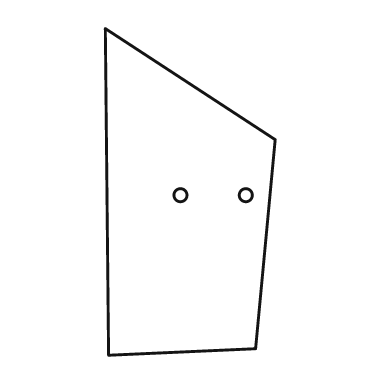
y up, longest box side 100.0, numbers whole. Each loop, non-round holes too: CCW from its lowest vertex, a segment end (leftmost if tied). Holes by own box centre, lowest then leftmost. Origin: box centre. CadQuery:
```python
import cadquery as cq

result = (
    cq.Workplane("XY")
    .moveTo(-25.0, -50.0)
    .lineTo(20.0, -48.0)
    .lineTo(26.0, 16.0)
    .lineTo(-26.0, 50.0)
    .close()
    .moveTo(-3.0, -1.0)
    .circle(2.0)
    .moveTo(17.0, -1.0)
    .circle(2.0)
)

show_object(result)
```